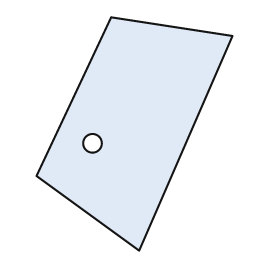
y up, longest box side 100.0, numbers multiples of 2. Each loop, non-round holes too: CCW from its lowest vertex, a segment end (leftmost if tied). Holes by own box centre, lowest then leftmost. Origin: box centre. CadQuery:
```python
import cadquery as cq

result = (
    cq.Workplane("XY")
    .moveTo(2.0, -50.0)
    .lineTo(42.0, 42.0)
    .lineTo(-10.0, 50.0)
    .lineTo(-42.0, -18.0)
    .close()
    .moveTo(-18.0, -4.0)
    .circle(4.0)
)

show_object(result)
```